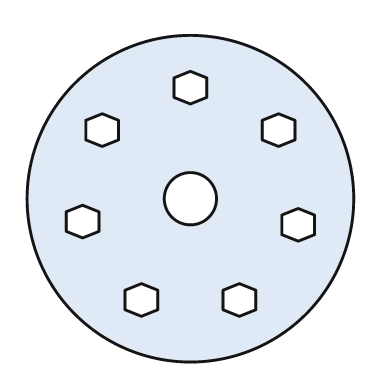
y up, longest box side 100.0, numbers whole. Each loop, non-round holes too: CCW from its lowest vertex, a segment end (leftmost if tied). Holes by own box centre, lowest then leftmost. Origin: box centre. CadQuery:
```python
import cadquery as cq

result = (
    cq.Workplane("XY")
    .moveTo(0.0, 0.0)
    .circle(50.0)
    .moveTo(-15.0, -36.0)
    .lineTo(-10.0, -34.0)
    .lineTo(-10.0, -28.0)
    .lineTo(-15.0, -26.0)
    .lineTo(-20.0, -28.0)
    .lineTo(-20.0, -34.0)
    .close()
    .moveTo(15.0, -36.0)
    .lineTo(20.0, -34.0)
    .lineTo(20.0, -28.0)
    .lineTo(15.0, -26.0)
    .lineTo(10.0, -28.0)
    .lineTo(10.0, -34.0)
    .close()
    .moveTo(33.0, -13.0)
    .lineTo(38.0, -11.0)
    .lineTo(38.0, -5.0)
    .lineTo(33.0, -3.0)
    .lineTo(28.0, -5.0)
    .lineTo(28.0, -11.0)
    .close()
    .moveTo(-33.0, -12.0)
    .lineTo(-28.0, -10.0)
    .lineTo(-28.0, -4.0)
    .lineTo(-33.0, -2.0)
    .lineTo(-38.0, -4.0)
    .lineTo(-38.0, -10.0)
    .close()
    .moveTo(0.0, 0.0)
    .circle(8.0)
    .moveTo(-27.0, 16.0)
    .lineTo(-22.0, 18.0)
    .lineTo(-22.0, 24.0)
    .lineTo(-27.0, 26.0)
    .lineTo(-32.0, 24.0)
    .lineTo(-32.0, 18.0)
    .close()
    .moveTo(27.0, 16.0)
    .lineTo(32.0, 18.0)
    .lineTo(32.0, 24.0)
    .lineTo(27.0, 26.0)
    .lineTo(22.0, 24.0)
    .lineTo(22.0, 18.0)
    .close()
    .moveTo(0.0, 29.0)
    .lineTo(5.0, 31.0)
    .lineTo(5.0, 37.0)
    .lineTo(0.0, 39.0)
    .lineTo(-5.0, 37.0)
    .lineTo(-5.0, 31.0)
    .close()
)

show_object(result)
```